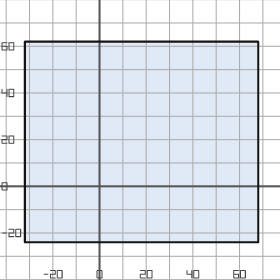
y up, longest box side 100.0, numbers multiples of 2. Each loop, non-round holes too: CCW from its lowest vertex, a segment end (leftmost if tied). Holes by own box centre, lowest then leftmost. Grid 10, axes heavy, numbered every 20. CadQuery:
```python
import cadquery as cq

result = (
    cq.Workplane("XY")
    .moveTo(-32.0, -24.0)
    .lineTo(68.0, -24.0)
    .lineTo(68.0, 62.0)
    .lineTo(-32.0, 62.0)
    .close()
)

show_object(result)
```